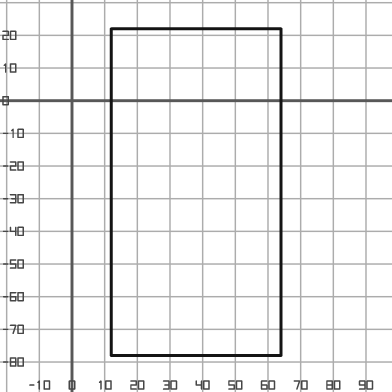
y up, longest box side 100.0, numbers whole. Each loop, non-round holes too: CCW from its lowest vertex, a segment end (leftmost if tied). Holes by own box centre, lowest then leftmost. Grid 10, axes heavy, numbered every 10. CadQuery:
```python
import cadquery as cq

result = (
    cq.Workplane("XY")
    .moveTo(12.0, -78.0)
    .lineTo(64.0, -78.0)
    .lineTo(64.0, 22.0)
    .lineTo(12.0, 22.0)
    .close()
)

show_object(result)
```